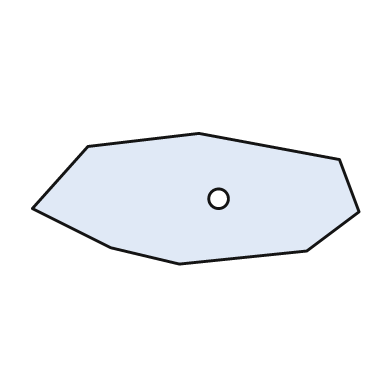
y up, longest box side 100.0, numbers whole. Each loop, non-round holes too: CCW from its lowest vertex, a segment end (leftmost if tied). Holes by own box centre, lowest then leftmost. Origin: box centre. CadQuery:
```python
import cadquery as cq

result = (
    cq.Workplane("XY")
    .moveTo(-5.0, -20.0)
    .lineTo(34.0, -16.0)
    .lineTo(50.0, -4.0)
    .lineTo(44.0, 12.0)
    .lineTo(1.0, 20.0)
    .lineTo(-33.0, 16.0)
    .lineTo(-50.0, -3.0)
    .lineTo(-26.0, -15.0)
    .close()
    .moveTo(7.0, 0.0)
    .circle(3.0)
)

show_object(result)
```